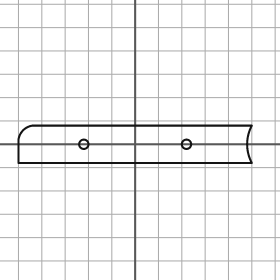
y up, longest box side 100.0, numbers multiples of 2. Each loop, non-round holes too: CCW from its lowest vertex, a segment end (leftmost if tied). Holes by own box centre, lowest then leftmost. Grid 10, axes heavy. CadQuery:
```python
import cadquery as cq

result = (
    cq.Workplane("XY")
    .moveTo(-50.0, -8.0)
    .lineTo(50.0, -8.0)
    .threePointArc((48.0, 0.0), (50.0, 8.0))
    .lineTo(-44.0, 8.0)
    .threePointArc((-48.0, 6.0), (-50.0, 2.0))
    .close()
    .moveTo(-22.0, 0.0)
    .circle(2.0)
    .moveTo(22.0, 0.0)
    .circle(2.0)
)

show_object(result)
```